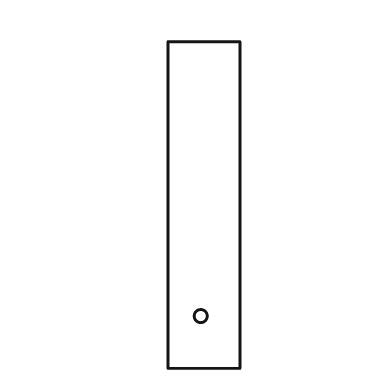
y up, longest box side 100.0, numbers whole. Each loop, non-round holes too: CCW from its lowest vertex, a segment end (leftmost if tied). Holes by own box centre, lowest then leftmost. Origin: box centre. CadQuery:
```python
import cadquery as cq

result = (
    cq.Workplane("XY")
    .moveTo(-11.0, -50.0)
    .lineTo(11.0, -50.0)
    .lineTo(11.0, 50.0)
    .lineTo(-11.0, 50.0)
    .close()
    .moveTo(-1.0, -34.0)
    .circle(2.0)
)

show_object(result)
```